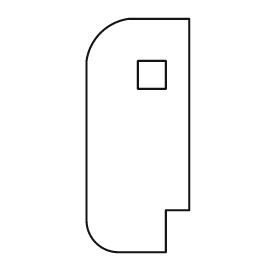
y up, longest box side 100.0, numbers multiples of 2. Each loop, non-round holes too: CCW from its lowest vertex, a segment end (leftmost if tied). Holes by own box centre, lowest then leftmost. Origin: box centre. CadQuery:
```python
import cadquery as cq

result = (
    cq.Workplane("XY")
    .moveTo(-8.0, -50.0)
    .lineTo(12.0, -50.0)
    .lineTo(12.0, -32.0)
    .lineTo(22.0, -32.0)
    .lineTo(22.0, 50.0)
    .lineTo(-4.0, 50.0)
    .threePointArc((-16.0, 44.0), (-22.0, 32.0))
    .lineTo(-22.0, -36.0)
    .threePointArc((-18.0, -46.0), (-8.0, -50.0))
    .close()
    .moveTo(0.0, 20.0)
    .lineTo(12.0, 20.0)
    .lineTo(12.0, 32.0)
    .lineTo(0.0, 32.0)
    .close()
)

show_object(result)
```